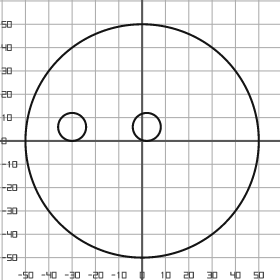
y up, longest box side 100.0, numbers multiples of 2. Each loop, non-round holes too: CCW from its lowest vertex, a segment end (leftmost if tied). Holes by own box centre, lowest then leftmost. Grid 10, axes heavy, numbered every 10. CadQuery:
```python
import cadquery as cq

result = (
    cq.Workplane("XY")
    .moveTo(0.0, 0.0)
    .circle(50.0)
    .moveTo(-30.0, 6.0)
    .circle(6.0)
    .moveTo(2.0, 6.0)
    .circle(6.0)
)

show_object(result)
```